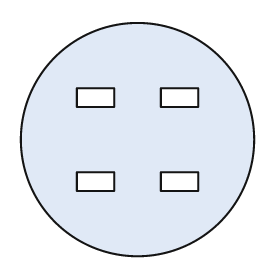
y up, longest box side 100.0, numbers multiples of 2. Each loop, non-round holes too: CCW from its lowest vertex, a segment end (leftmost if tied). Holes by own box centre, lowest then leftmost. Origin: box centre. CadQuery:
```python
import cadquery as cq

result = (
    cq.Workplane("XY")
    .moveTo(0.0, 0.0)
    .circle(50.0)
    .moveTo(-26.0, -22.0)
    .lineTo(-10.0, -22.0)
    .lineTo(-10.0, -14.0)
    .lineTo(-26.0, -14.0)
    .close()
    .moveTo(10.0, -22.0)
    .lineTo(26.0, -22.0)
    .lineTo(26.0, -14.0)
    .lineTo(10.0, -14.0)
    .close()
    .moveTo(-26.0, 14.0)
    .lineTo(-10.0, 14.0)
    .lineTo(-10.0, 22.0)
    .lineTo(-26.0, 22.0)
    .close()
    .moveTo(10.0, 14.0)
    .lineTo(26.0, 14.0)
    .lineTo(26.0, 22.0)
    .lineTo(10.0, 22.0)
    .close()
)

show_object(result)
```